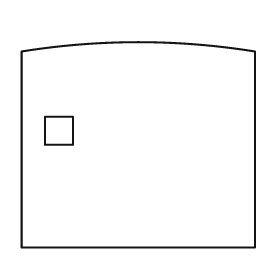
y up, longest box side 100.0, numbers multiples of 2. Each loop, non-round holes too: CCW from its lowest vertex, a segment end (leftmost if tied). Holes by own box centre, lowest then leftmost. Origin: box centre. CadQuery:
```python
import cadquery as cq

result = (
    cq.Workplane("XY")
    .moveTo(-50.0, -44.0)
    .lineTo(50.0, -44.0)
    .lineTo(50.0, 40.0)
    .threePointArc((0.0, 44.0), (-50.0, 40.0))
    .close()
    .moveTo(-40.0, 0.0)
    .lineTo(-28.0, 0.0)
    .lineTo(-28.0, 12.0)
    .lineTo(-40.0, 12.0)
    .close()
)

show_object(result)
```